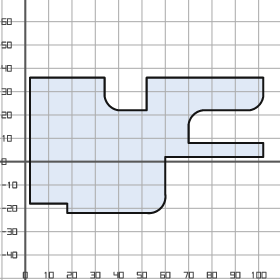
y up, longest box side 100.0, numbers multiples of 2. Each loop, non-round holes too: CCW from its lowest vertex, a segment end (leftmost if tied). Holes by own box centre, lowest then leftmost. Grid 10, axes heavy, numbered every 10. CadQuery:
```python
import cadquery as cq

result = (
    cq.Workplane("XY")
    .moveTo(18.0, -22.0)
    .lineTo(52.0, -22.0)
    .threePointArc((58.0, -20.0), (60.0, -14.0))
    .lineTo(60.0, 2.0)
    .lineTo(102.0, 2.0)
    .lineTo(102.0, 8.0)
    .lineTo(70.0, 8.0)
    .lineTo(70.0, 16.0)
    .threePointArc((72.0, 20.0), (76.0, 22.0))
    .lineTo(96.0, 22.0)
    .threePointArc((100.0, 24.0), (102.0, 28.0))
    .lineTo(102.0, 36.0)
    .lineTo(52.0, 36.0)
    .lineTo(52.0, 22.0)
    .lineTo(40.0, 22.0)
    .threePointArc((36.0, 24.0), (34.0, 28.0))
    .lineTo(34.0, 36.0)
    .lineTo(2.0, 36.0)
    .lineTo(2.0, -18.0)
    .lineTo(18.0, -18.0)
    .close()
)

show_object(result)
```